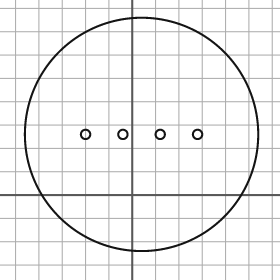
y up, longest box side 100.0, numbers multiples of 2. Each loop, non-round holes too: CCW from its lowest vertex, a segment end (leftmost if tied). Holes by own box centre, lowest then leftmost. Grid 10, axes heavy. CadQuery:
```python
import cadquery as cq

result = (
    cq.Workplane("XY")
    .moveTo(4.0, 26.0)
    .circle(50.0)
    .moveTo(-20.0, 26.0)
    .circle(2.0)
    .moveTo(-4.0, 26.0)
    .circle(2.0)
    .moveTo(12.0, 26.0)
    .circle(2.0)
    .moveTo(28.0, 26.0)
    .circle(2.0)
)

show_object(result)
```